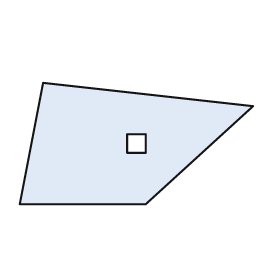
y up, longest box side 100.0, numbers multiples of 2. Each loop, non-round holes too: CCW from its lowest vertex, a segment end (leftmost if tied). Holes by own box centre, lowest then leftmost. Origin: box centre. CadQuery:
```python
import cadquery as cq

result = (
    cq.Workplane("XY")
    .moveTo(-50.0, -26.0)
    .lineTo(4.0, -26.0)
    .lineTo(50.0, 16.0)
    .lineTo(-40.0, 26.0)
    .close()
    .moveTo(-4.0, -4.0)
    .lineTo(4.0, -4.0)
    .lineTo(4.0, 4.0)
    .lineTo(-4.0, 4.0)
    .close()
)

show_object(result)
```